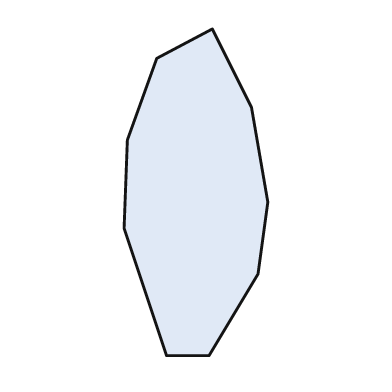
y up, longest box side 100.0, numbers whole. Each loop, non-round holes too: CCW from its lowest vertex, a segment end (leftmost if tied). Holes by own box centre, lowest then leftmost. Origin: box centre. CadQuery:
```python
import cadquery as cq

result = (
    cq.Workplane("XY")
    .moveTo(-9.0, -50.0)
    .lineTo(4.0, -50.0)
    .lineTo(19.0, -25.0)
    .lineTo(22.0, -3.0)
    .lineTo(17.0, 26.0)
    .lineTo(5.0, 50.0)
    .lineTo(-12.0, 41.0)
    .lineTo(-21.0, 16.0)
    .lineTo(-22.0, -11.0)
    .close()
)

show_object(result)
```